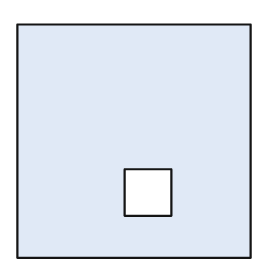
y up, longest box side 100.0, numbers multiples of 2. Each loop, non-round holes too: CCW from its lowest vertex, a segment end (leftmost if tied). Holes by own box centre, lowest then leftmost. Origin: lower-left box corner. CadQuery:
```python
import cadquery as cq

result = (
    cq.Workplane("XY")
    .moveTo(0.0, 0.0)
    .lineTo(100.0, 0.0)
    .lineTo(100.0, 100.0)
    .lineTo(0.0, 100.0)
    .close()
    .moveTo(46.0, 18.0)
    .lineTo(66.0, 18.0)
    .lineTo(66.0, 38.0)
    .lineTo(46.0, 38.0)
    .close()
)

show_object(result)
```